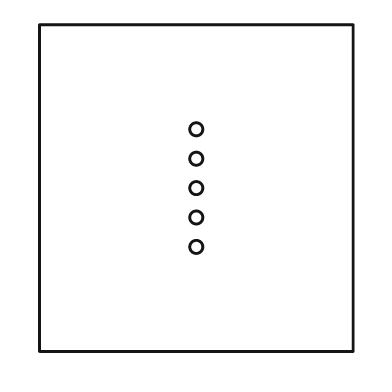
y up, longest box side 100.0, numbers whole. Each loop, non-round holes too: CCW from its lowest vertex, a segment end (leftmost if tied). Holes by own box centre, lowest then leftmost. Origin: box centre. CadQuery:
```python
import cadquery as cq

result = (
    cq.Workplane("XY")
    .moveTo(-48.0, -50.0)
    .lineTo(48.0, -50.0)
    .lineTo(48.0, 50.0)
    .lineTo(-48.0, 50.0)
    .close()
    .moveTo(0.0, -18.0)
    .circle(2.0)
    .moveTo(0.0, -9.0)
    .circle(2.0)
    .moveTo(0.0, 0.0)
    .circle(2.0)
    .moveTo(0.0, 9.0)
    .circle(2.0)
    .moveTo(0.0, 18.0)
    .circle(2.0)
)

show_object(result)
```